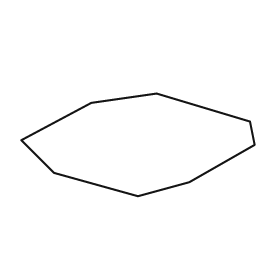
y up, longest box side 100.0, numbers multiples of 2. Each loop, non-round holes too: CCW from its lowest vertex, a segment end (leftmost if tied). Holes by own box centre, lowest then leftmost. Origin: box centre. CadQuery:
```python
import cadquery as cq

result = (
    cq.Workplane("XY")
    .moveTo(0.0, -22.0)
    .lineTo(22.0, -16.0)
    .lineTo(50.0, 0.0)
    .lineTo(48.0, 10.0)
    .lineTo(8.0, 22.0)
    .lineTo(-20.0, 18.0)
    .lineTo(-50.0, 2.0)
    .lineTo(-36.0, -12.0)
    .close()
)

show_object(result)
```